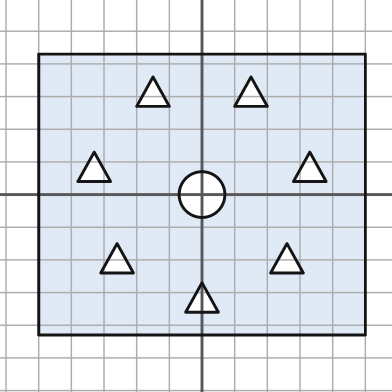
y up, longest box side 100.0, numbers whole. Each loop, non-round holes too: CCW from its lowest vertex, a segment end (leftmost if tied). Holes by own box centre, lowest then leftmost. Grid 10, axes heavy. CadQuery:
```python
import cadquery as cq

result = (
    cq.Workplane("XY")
    .moveTo(-50.0, -43.0)
    .lineTo(50.0, -43.0)
    .lineTo(50.0, 43.0)
    .lineTo(-50.0, 43.0)
    .close()
    .moveTo(-5.0, -36.0)
    .lineTo(5.0, -36.0)
    .lineTo(0.0, -27.0)
    .close()
    .moveTo(-31.0, -24.0)
    .lineTo(-21.0, -24.0)
    .lineTo(-26.0, -15.0)
    .close()
    .moveTo(21.0, -24.0)
    .lineTo(31.0, -24.0)
    .lineTo(26.0, -15.0)
    .close()
    .moveTo(0.0, 0.0)
    .circle(7.0)
    .moveTo(-38.0, 4.0)
    .lineTo(-28.0, 4.0)
    .lineTo(-33.0, 13.0)
    .close()
    .moveTo(28.0, 4.0)
    .lineTo(38.0, 4.0)
    .lineTo(33.0, 13.0)
    .close()
    .moveTo(-20.0, 27.0)
    .lineTo(-10.0, 27.0)
    .lineTo(-15.0, 36.0)
    .close()
    .moveTo(10.0, 27.0)
    .lineTo(20.0, 27.0)
    .lineTo(15.0, 36.0)
    .close()
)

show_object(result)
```